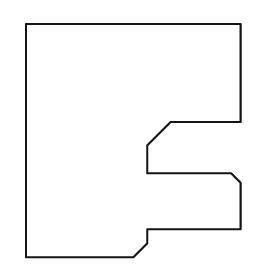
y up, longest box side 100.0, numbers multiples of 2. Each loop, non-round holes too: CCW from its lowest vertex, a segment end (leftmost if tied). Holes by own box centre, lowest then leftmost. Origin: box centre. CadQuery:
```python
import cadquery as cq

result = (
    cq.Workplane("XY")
    .moveTo(-46.0, -50.0)
    .lineTo(0.0, -50.0)
    .lineTo(6.0, -44.0)
    .lineTo(6.0, -38.0)
    .lineTo(46.0, -38.0)
    .lineTo(46.0, -18.0)
    .lineTo(42.0, -14.0)
    .lineTo(6.0, -14.0)
    .lineTo(6.0, -2.0)
    .lineTo(16.0, 8.0)
    .lineTo(46.0, 8.0)
    .lineTo(46.0, 50.0)
    .lineTo(-46.0, 50.0)
    .close()
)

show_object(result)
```